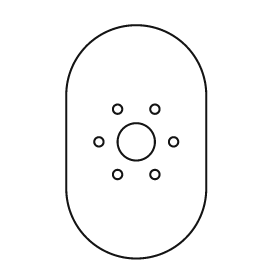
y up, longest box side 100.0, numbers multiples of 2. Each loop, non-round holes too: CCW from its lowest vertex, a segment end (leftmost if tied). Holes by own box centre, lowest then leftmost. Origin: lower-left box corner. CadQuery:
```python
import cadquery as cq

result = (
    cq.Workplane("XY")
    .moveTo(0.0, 30.0)
    .threePointArc((30.0, 0.0), (60.0, 30.0))
    .lineTo(60.0, 70.0)
    .threePointArc((30.0, 100.0), (0.0, 70.0))
    .close()
    .moveTo(22.0, 36.0)
    .circle(2.0)
    .moveTo(38.0, 36.0)
    .circle(2.0)
    .moveTo(14.0, 50.0)
    .circle(2.0)
    .moveTo(30.0, 50.0)
    .circle(8.0)
    .moveTo(46.0, 50.0)
    .circle(2.0)
    .moveTo(22.0, 64.0)
    .circle(2.0)
    .moveTo(38.0, 64.0)
    .circle(2.0)
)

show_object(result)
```